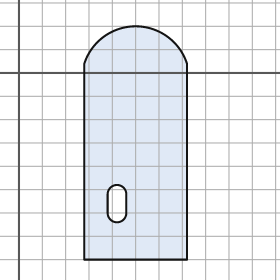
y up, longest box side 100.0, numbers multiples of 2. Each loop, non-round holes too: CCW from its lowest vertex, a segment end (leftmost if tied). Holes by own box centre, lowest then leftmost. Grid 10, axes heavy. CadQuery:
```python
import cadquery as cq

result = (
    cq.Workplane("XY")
    .moveTo(28.0, -80.0)
    .lineTo(72.0, -80.0)
    .lineTo(72.0, 4.0)
    .threePointArc((50.0, 20.0), (28.0, 4.0))
    .close()
    .moveTo(38.0, -60.0)
    .threePointArc((42.0, -64.0), (46.0, -60.0))
    .lineTo(46.0, -52.0)
    .threePointArc((42.0, -48.0), (38.0, -52.0))
    .close()
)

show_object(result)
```